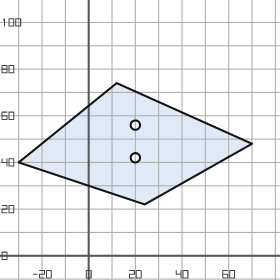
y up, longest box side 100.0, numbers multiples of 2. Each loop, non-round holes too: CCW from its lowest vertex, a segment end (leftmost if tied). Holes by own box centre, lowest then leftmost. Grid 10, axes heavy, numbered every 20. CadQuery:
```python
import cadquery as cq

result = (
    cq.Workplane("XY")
    .moveTo(24.0, 22.0)
    .lineTo(70.0, 48.0)
    .lineTo(12.0, 74.0)
    .lineTo(-30.0, 40.0)
    .close()
    .moveTo(20.0, 42.0)
    .circle(2.0)
    .moveTo(20.0, 56.0)
    .circle(2.0)
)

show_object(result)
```